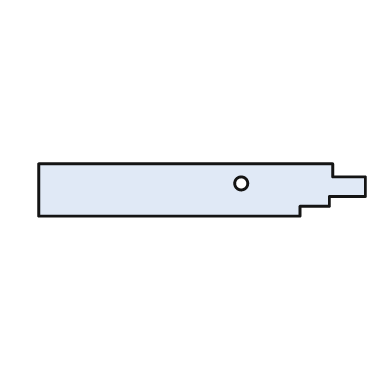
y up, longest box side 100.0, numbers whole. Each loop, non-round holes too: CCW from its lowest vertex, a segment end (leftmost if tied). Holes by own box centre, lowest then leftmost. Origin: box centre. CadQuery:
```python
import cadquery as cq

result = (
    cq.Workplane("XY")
    .moveTo(-50.0, -8.0)
    .lineTo(30.0, -8.0)
    .lineTo(30.0, -5.0)
    .lineTo(39.0, -5.0)
    .lineTo(39.0, -2.0)
    .lineTo(50.0, -2.0)
    .lineTo(50.0, 4.0)
    .lineTo(40.0, 4.0)
    .lineTo(40.0, 8.0)
    .lineTo(-50.0, 8.0)
    .close()
    .moveTo(12.0, 2.0)
    .circle(2.0)
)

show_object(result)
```